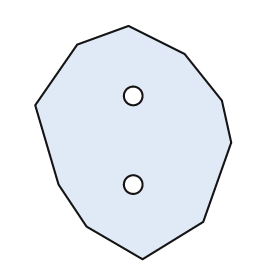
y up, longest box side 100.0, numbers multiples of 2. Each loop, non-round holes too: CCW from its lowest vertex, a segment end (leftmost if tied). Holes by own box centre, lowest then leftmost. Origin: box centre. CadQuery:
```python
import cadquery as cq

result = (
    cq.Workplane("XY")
    .moveTo(4.0, -50.0)
    .lineTo(30.0, -34.0)
    .lineTo(42.0, 0.0)
    .lineTo(38.0, 18.0)
    .lineTo(22.0, 38.0)
    .lineTo(-2.0, 50.0)
    .lineTo(-24.0, 42.0)
    .lineTo(-42.0, 16.0)
    .lineTo(-32.0, -18.0)
    .lineTo(-20.0, -36.0)
    .close()
    .moveTo(0.0, -18.0)
    .circle(4.0)
    .moveTo(0.0, 20.0)
    .circle(4.0)
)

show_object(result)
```